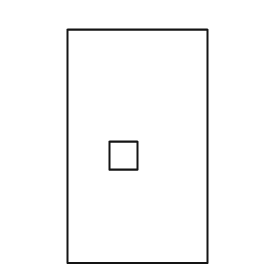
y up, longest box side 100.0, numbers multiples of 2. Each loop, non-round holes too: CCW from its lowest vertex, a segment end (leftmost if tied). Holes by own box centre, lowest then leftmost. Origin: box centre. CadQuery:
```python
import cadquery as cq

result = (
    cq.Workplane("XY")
    .moveTo(-30.0, -50.0)
    .lineTo(30.0, -50.0)
    .lineTo(30.0, 50.0)
    .lineTo(-30.0, 50.0)
    .close()
    .moveTo(-12.0, -10.0)
    .lineTo(0.0, -10.0)
    .lineTo(0.0, 2.0)
    .lineTo(-12.0, 2.0)
    .close()
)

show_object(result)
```